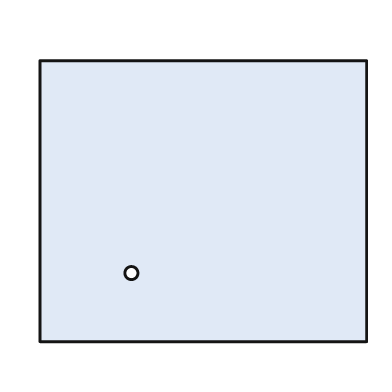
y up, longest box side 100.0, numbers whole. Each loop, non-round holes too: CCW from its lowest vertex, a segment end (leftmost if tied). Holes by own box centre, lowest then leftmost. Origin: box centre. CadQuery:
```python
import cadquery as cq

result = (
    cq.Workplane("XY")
    .moveTo(-50.0, -43.0)
    .lineTo(50.0, -43.0)
    .lineTo(50.0, 43.0)
    .lineTo(-50.0, 43.0)
    .close()
    .moveTo(-22.0, -22.0)
    .circle(2.0)
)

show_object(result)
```